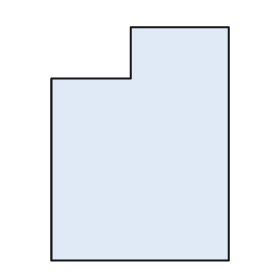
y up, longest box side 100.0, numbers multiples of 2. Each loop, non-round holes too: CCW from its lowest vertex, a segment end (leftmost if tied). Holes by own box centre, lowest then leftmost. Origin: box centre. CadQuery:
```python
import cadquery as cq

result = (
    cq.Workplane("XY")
    .moveTo(-38.0, -50.0)
    .lineTo(38.0, -50.0)
    .lineTo(38.0, 50.0)
    .lineTo(-4.0, 50.0)
    .lineTo(-4.0, 28.0)
    .lineTo(-38.0, 28.0)
    .close()
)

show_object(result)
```